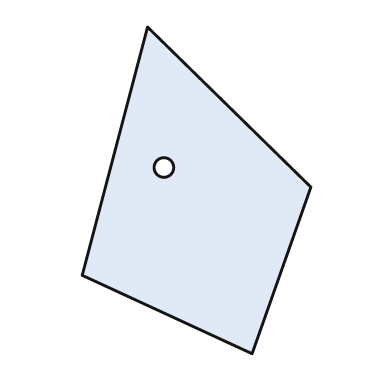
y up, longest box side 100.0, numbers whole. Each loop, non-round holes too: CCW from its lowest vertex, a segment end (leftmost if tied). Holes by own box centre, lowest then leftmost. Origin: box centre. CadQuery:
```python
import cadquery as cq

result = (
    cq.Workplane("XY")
    .moveTo(17.0, -50.0)
    .lineTo(35.0, 1.0)
    .lineTo(-15.0, 50.0)
    .lineTo(-35.0, -26.0)
    .close()
    .moveTo(-10.0, 7.0)
    .circle(3.0)
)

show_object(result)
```